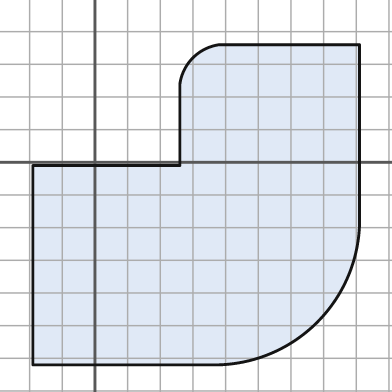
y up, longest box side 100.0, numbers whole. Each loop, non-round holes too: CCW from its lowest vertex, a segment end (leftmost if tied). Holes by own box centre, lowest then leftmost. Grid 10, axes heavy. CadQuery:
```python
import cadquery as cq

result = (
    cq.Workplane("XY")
    .moveTo(-19.0, -62.0)
    .lineTo(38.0, -62.0)
    .threePointArc((68.0, -49.0), (81.0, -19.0))
    .lineTo(81.0, 36.0)
    .lineTo(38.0, 36.0)
    .threePointArc((30.0, 32.0), (26.0, 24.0))
    .lineTo(26.0, -1.0)
    .lineTo(-19.0, -1.0)
    .close()
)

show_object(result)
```